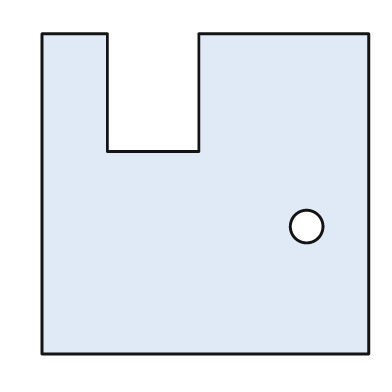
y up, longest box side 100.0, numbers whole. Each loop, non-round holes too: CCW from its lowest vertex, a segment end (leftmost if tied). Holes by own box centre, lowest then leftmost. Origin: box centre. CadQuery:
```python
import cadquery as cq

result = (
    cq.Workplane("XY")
    .moveTo(-50.0, -49.0)
    .lineTo(50.0, -49.0)
    .lineTo(50.0, 49.0)
    .lineTo(-2.0, 49.0)
    .lineTo(-2.0, 13.0)
    .lineTo(-30.0, 13.0)
    .lineTo(-30.0, 49.0)
    .lineTo(-50.0, 49.0)
    .close()
    .moveTo(31.0, -10.0)
    .circle(5.0)
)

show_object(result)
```